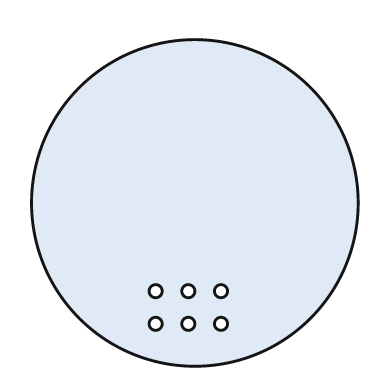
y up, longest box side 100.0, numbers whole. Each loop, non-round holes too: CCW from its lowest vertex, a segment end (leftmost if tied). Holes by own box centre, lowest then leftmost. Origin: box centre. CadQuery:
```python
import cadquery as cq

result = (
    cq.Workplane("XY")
    .moveTo(0.0, 0.0)
    .circle(50.0)
    .moveTo(-12.0, -37.0)
    .circle(2.0)
    .moveTo(-2.0, -37.0)
    .circle(2.0)
    .moveTo(8.0, -37.0)
    .circle(2.0)
    .moveTo(-12.0, -27.0)
    .circle(2.0)
    .moveTo(-2.0, -27.0)
    .circle(2.0)
    .moveTo(8.0, -27.0)
    .circle(2.0)
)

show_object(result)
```